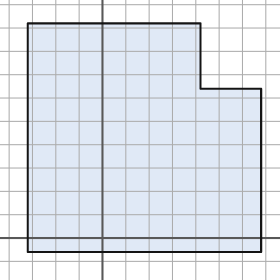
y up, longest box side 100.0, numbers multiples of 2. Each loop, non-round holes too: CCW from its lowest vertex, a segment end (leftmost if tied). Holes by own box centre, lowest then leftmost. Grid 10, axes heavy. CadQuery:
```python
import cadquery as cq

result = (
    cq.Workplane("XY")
    .moveTo(-32.0, -6.0)
    .lineTo(68.0, -6.0)
    .lineTo(68.0, 64.0)
    .lineTo(42.0, 64.0)
    .lineTo(42.0, 92.0)
    .lineTo(-32.0, 92.0)
    .close()
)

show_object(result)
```